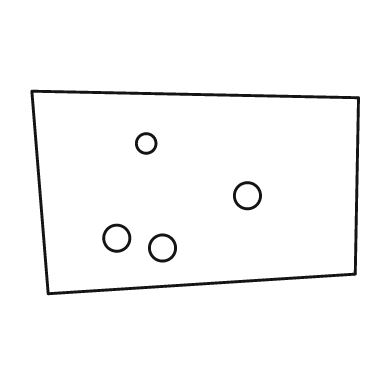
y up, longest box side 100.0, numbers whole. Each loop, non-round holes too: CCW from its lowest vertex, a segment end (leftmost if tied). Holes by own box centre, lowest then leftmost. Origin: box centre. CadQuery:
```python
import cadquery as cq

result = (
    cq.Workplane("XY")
    .moveTo(-45.0, -31.0)
    .lineTo(49.0, -25.0)
    .lineTo(50.0, 29.0)
    .lineTo(-50.0, 31.0)
    .close()
    .moveTo(-10.0, -17.0)
    .circle(4.0)
    .moveTo(-24.0, -14.0)
    .circle(4.0)
    .moveTo(16.0, -1.0)
    .circle(4.0)
    .moveTo(-15.0, 15.0)
    .circle(3.0)
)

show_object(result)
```